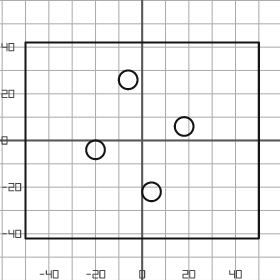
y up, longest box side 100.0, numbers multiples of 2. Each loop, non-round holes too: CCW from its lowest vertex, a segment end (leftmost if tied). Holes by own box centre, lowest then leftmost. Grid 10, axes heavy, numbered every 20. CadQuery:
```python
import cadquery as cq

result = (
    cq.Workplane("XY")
    .moveTo(-50.0, -42.0)
    .lineTo(50.0, -42.0)
    .lineTo(50.0, 42.0)
    .lineTo(-50.0, 42.0)
    .close()
    .moveTo(4.0, -22.0)
    .circle(4.0)
    .moveTo(-20.0, -4.0)
    .circle(4.0)
    .moveTo(18.0, 6.0)
    .circle(4.0)
    .moveTo(-6.0, 26.0)
    .circle(4.0)
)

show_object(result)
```